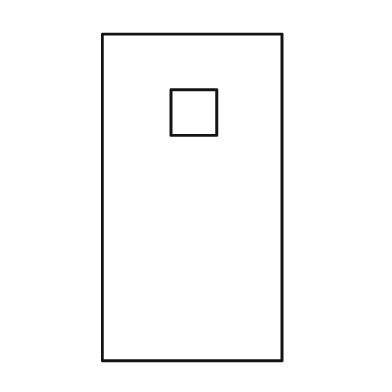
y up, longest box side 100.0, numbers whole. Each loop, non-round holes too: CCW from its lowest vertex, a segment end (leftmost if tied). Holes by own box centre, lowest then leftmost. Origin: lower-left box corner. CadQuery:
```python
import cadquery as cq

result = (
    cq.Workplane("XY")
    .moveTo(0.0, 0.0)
    .lineTo(55.0, 0.0)
    .lineTo(55.0, 100.0)
    .lineTo(0.0, 100.0)
    .close()
    .moveTo(21.0, 69.0)
    .lineTo(35.0, 69.0)
    .lineTo(35.0, 83.0)
    .lineTo(21.0, 83.0)
    .close()
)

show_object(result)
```